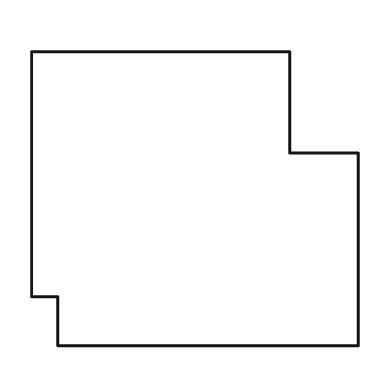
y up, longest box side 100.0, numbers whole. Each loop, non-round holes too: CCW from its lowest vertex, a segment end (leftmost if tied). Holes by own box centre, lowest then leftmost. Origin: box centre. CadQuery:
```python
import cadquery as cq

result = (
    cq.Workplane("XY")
    .moveTo(-42.0, -45.0)
    .lineTo(50.0, -45.0)
    .lineTo(50.0, 14.0)
    .lineTo(29.0, 14.0)
    .lineTo(29.0, 45.0)
    .lineTo(-50.0, 45.0)
    .lineTo(-50.0, -30.0)
    .lineTo(-42.0, -30.0)
    .close()
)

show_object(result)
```